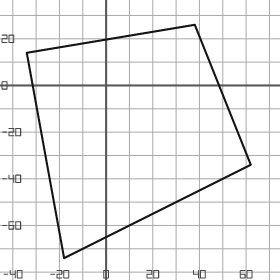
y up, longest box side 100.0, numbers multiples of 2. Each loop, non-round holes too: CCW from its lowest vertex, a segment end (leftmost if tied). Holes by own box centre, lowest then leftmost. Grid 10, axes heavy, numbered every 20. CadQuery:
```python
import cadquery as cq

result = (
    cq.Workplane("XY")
    .moveTo(-18.0, -74.0)
    .lineTo(62.0, -34.0)
    .lineTo(38.0, 26.0)
    .lineTo(-34.0, 14.0)
    .close()
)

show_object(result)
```